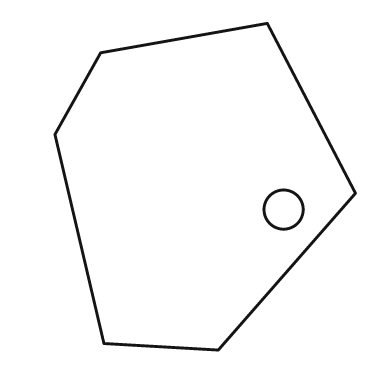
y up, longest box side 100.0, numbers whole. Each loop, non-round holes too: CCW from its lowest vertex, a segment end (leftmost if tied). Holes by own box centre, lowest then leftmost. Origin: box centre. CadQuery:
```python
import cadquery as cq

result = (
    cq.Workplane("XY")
    .moveTo(4.0, -50.0)
    .lineTo(46.0, -2.0)
    .lineTo(19.0, 50.0)
    .lineTo(-32.0, 41.0)
    .lineTo(-46.0, 16.0)
    .lineTo(-31.0, -48.0)
    .close()
    .moveTo(24.0, -7.0)
    .circle(6.0)
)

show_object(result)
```